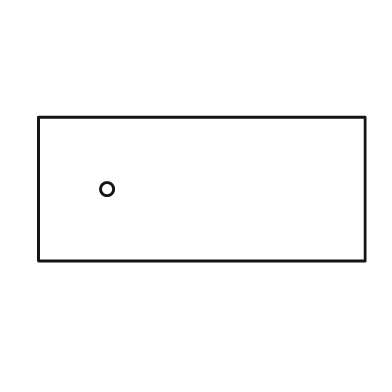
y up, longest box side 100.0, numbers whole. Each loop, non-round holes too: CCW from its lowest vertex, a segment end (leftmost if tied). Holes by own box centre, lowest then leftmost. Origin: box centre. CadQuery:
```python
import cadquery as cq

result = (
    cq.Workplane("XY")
    .moveTo(-50.0, -22.0)
    .lineTo(50.0, -22.0)
    .lineTo(50.0, 22.0)
    .lineTo(-50.0, 22.0)
    .close()
    .moveTo(-29.0, 0.0)
    .circle(2.0)
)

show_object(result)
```